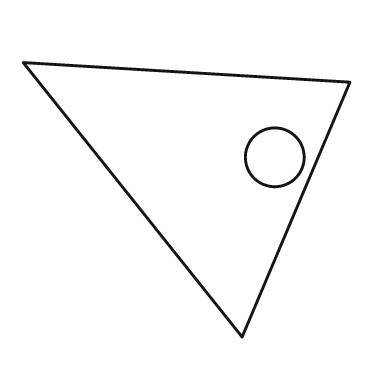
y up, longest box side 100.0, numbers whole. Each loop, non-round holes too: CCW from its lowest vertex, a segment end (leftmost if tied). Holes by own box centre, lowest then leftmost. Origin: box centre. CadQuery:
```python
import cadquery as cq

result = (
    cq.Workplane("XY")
    .moveTo(17.0, -42.0)
    .lineTo(50.0, 36.0)
    .lineTo(-50.0, 42.0)
    .close()
    .moveTo(27.0, 13.0)
    .circle(9.0)
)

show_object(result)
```